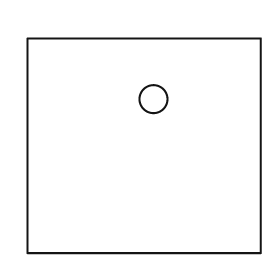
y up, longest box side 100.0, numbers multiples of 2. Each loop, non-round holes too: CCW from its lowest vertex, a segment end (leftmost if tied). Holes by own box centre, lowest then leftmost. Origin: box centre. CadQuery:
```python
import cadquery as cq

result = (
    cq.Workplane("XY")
    .moveTo(-50.0, -46.0)
    .lineTo(50.0, -46.0)
    .lineTo(50.0, 46.0)
    .lineTo(-50.0, 46.0)
    .close()
    .moveTo(4.0, 20.0)
    .circle(6.0)
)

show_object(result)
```